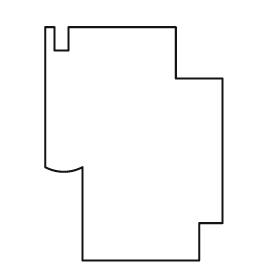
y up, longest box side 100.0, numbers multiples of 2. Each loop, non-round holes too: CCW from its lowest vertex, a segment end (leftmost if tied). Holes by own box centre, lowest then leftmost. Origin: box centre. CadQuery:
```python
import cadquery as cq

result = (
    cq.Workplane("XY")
    .moveTo(-22.0, -50.0)
    .lineTo(28.0, -50.0)
    .lineTo(28.0, -34.0)
    .lineTo(38.0, -34.0)
    .lineTo(38.0, 28.0)
    .lineTo(18.0, 28.0)
    .lineTo(18.0, 50.0)
    .lineTo(-28.0, 50.0)
    .lineTo(-28.0, 40.0)
    .lineTo(-34.0, 40.0)
    .lineTo(-34.0, 50.0)
    .lineTo(-38.0, 50.0)
    .lineTo(-38.0, -10.0)
    .threePointArc((-30.0, -12.0), (-22.0, -10.0))
    .close()
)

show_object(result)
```